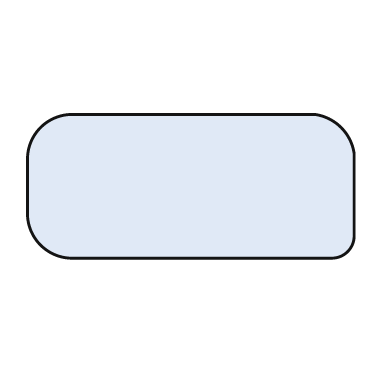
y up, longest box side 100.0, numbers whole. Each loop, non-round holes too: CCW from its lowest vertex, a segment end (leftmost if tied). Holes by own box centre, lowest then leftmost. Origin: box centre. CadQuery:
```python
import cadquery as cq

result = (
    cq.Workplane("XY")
    .moveTo(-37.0, -22.0)
    .lineTo(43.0, -22.0)
    .threePointArc((48.0, -20.0), (50.0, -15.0))
    .lineTo(50.0, 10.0)
    .threePointArc((46.0, 18.0), (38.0, 22.0))
    .lineTo(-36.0, 22.0)
    .threePointArc((-46.0, 18.0), (-50.0, 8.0))
    .lineTo(-50.0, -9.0)
    .threePointArc((-46.0, -18.0), (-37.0, -22.0))
    .close()
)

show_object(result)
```